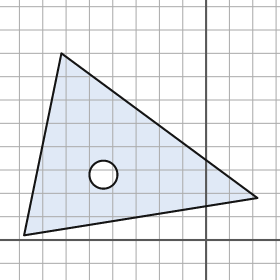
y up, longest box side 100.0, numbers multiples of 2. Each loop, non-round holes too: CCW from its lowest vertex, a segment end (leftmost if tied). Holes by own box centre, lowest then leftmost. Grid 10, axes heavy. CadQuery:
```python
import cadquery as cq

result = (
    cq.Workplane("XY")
    .moveTo(-78.0, 2.0)
    .lineTo(22.0, 18.0)
    .lineTo(-62.0, 80.0)
    .close()
    .moveTo(-44.0, 28.0)
    .circle(6.0)
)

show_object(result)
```